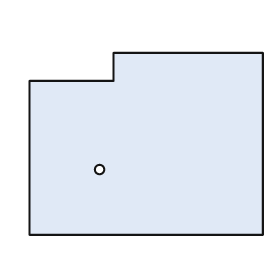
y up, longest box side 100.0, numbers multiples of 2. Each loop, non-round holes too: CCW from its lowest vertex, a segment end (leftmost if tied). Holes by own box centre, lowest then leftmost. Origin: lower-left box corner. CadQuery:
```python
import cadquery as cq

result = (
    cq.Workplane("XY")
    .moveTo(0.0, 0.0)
    .lineTo(100.0, 0.0)
    .lineTo(100.0, 78.0)
    .lineTo(36.0, 78.0)
    .lineTo(36.0, 66.0)
    .lineTo(0.0, 66.0)
    .close()
    .moveTo(30.0, 28.0)
    .circle(2.0)
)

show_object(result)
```